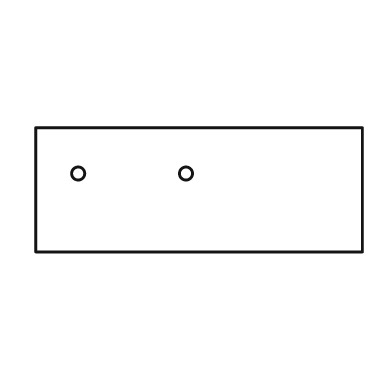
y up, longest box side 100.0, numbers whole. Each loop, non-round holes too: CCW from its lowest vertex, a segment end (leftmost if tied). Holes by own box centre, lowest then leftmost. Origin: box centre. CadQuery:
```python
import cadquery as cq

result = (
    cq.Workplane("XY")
    .moveTo(-50.0, -19.0)
    .lineTo(50.0, -19.0)
    .lineTo(50.0, 19.0)
    .lineTo(-50.0, 19.0)
    .close()
    .moveTo(-37.0, 5.0)
    .circle(2.0)
    .moveTo(-4.0, 5.0)
    .circle(2.0)
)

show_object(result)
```